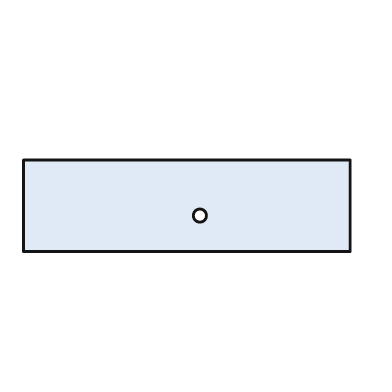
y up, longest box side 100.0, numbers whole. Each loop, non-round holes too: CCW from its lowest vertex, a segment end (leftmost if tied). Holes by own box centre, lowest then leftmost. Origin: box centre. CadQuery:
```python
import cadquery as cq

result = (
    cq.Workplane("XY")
    .moveTo(-50.0, -14.0)
    .lineTo(50.0, -14.0)
    .lineTo(50.0, 14.0)
    .lineTo(-50.0, 14.0)
    .close()
    .moveTo(4.0, -3.0)
    .circle(2.0)
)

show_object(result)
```